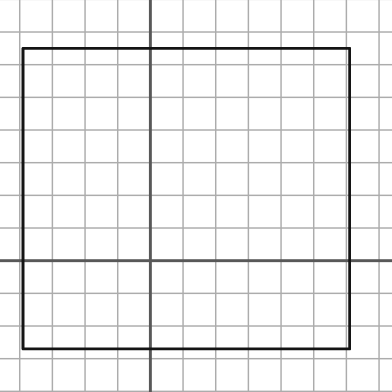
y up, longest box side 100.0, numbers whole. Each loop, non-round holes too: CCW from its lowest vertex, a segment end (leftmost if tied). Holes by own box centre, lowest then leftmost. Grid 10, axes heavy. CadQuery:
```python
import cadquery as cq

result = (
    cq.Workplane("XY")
    .moveTo(-39.0, -27.0)
    .lineTo(61.0, -27.0)
    .lineTo(61.0, 65.0)
    .lineTo(-39.0, 65.0)
    .close()
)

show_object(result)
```